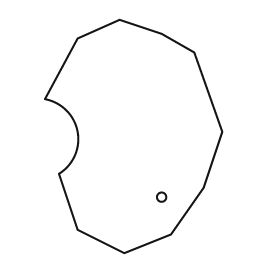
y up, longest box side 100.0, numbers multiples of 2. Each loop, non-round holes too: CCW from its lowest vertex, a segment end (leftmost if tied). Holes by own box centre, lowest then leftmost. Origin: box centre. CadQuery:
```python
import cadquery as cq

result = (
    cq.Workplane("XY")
    .moveTo(-4.0, -50.0)
    .lineTo(16.0, -42.0)
    .lineTo(30.0, -22.0)
    .lineTo(38.0, 2.0)
    .lineTo(26.0, 36.0)
    .lineTo(12.0, 44.0)
    .lineTo(-6.0, 50.0)
    .lineTo(-24.0, 42.0)
    .lineTo(-38.0, 16.0)
    .threePointArc((-24.0, 2.0), (-32.0, -16.0))
    .lineTo(-24.0, -40.0)
    .close()
    .moveTo(12.0, -26.0)
    .circle(2.0)
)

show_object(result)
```